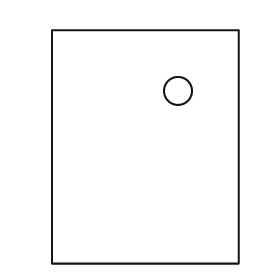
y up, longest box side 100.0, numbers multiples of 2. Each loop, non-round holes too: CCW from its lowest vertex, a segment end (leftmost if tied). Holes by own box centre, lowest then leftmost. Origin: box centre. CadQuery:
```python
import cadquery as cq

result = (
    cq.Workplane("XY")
    .moveTo(-40.0, -50.0)
    .lineTo(40.0, -50.0)
    .lineTo(40.0, 50.0)
    .lineTo(-40.0, 50.0)
    .close()
    .moveTo(14.0, 24.0)
    .circle(6.0)
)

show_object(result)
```